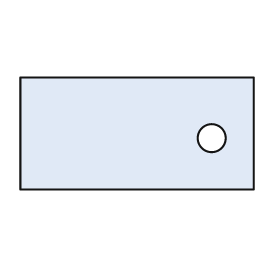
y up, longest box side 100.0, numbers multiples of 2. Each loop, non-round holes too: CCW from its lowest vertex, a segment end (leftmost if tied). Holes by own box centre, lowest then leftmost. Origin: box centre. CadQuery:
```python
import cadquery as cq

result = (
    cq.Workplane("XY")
    .moveTo(-50.0, -24.0)
    .lineTo(50.0, -24.0)
    .lineTo(50.0, 24.0)
    .lineTo(-50.0, 24.0)
    .close()
    .moveTo(32.0, -2.0)
    .circle(6.0)
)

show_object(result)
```